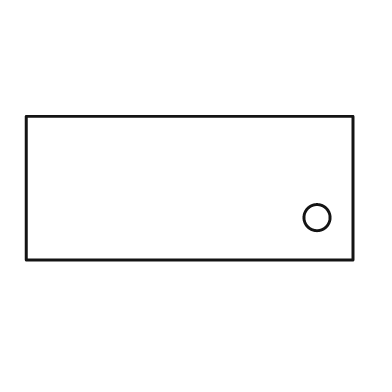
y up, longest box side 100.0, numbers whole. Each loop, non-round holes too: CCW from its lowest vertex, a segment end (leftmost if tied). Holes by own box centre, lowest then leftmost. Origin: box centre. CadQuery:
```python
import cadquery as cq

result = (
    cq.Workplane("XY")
    .moveTo(-50.0, -22.0)
    .lineTo(50.0, -22.0)
    .lineTo(50.0, 22.0)
    .lineTo(-50.0, 22.0)
    .close()
    .moveTo(39.0, -9.0)
    .circle(4.0)
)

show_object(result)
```